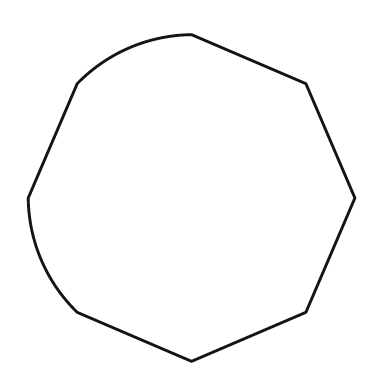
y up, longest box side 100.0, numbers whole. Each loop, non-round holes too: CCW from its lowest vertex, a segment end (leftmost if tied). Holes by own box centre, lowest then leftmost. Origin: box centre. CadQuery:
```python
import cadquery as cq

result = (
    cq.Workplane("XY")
    .moveTo(0.0, -50.0)
    .lineTo(35.0, -35.0)
    .lineTo(50.0, 0.0)
    .lineTo(35.0, 35.0)
    .lineTo(0.0, 50.0)
    .threePointArc((-19.0, 46.0), (-35.0, 35.0))
    .lineTo(-50.0, 0.0)
    .threePointArc((-46.0, -19.0), (-35.0, -35.0))
    .close()
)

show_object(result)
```